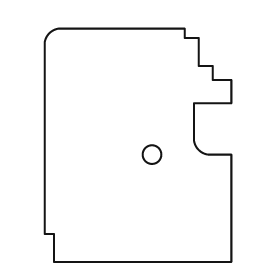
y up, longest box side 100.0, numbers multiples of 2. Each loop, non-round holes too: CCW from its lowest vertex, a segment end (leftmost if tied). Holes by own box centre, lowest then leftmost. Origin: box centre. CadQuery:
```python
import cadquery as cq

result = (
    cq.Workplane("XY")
    .moveTo(-36.0, -50.0)
    .lineTo(40.0, -50.0)
    .lineTo(40.0, -4.0)
    .lineTo(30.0, -4.0)
    .threePointArc((26.0, -2.0), (24.0, 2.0))
    .lineTo(24.0, 18.0)
    .lineTo(40.0, 18.0)
    .lineTo(40.0, 28.0)
    .lineTo(32.0, 28.0)
    .lineTo(32.0, 34.0)
    .lineTo(26.0, 34.0)
    .lineTo(26.0, 46.0)
    .lineTo(20.0, 46.0)
    .lineTo(20.0, 50.0)
    .lineTo(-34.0, 50.0)
    .threePointArc((-38.0, 48.0), (-40.0, 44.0))
    .lineTo(-40.0, -38.0)
    .lineTo(-36.0, -38.0)
    .close()
    .moveTo(6.0, -4.0)
    .circle(4.0)
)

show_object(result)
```